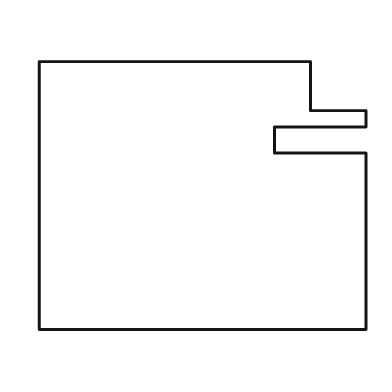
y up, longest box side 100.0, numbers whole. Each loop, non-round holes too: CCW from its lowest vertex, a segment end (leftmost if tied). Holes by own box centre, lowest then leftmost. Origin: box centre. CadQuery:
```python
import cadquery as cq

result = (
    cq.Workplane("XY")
    .moveTo(-50.0, -41.0)
    .lineTo(50.0, -41.0)
    .lineTo(50.0, 13.0)
    .lineTo(22.0, 13.0)
    .lineTo(22.0, 21.0)
    .lineTo(50.0, 21.0)
    .lineTo(50.0, 26.0)
    .lineTo(33.0, 26.0)
    .lineTo(33.0, 41.0)
    .lineTo(-50.0, 41.0)
    .close()
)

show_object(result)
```